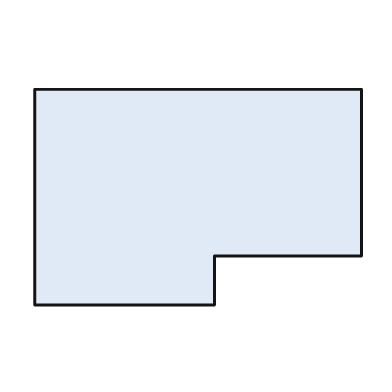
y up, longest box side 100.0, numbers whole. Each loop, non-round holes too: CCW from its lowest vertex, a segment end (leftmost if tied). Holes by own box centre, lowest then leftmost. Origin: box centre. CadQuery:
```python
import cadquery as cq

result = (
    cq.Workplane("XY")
    .moveTo(-50.0, -33.0)
    .lineTo(5.0, -33.0)
    .lineTo(5.0, -18.0)
    .lineTo(50.0, -18.0)
    .lineTo(50.0, 33.0)
    .lineTo(-50.0, 33.0)
    .close()
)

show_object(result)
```